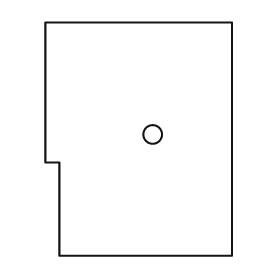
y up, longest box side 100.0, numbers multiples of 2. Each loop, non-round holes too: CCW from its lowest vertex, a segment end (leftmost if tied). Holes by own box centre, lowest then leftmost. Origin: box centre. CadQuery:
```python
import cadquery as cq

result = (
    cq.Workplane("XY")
    .moveTo(-34.0, -50.0)
    .lineTo(40.0, -50.0)
    .lineTo(40.0, 50.0)
    .lineTo(-40.0, 50.0)
    .lineTo(-40.0, -10.0)
    .lineTo(-34.0, -10.0)
    .close()
    .moveTo(6.0, 2.0)
    .circle(4.0)
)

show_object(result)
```